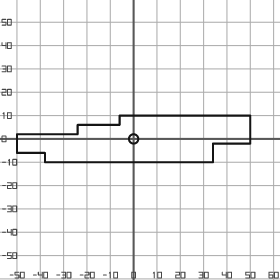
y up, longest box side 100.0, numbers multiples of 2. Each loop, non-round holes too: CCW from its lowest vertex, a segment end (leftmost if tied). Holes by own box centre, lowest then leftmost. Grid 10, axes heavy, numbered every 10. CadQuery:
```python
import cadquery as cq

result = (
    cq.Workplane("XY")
    .moveTo(-38.0, -10.0)
    .lineTo(34.0, -10.0)
    .lineTo(34.0, -2.0)
    .lineTo(50.0, -2.0)
    .lineTo(50.0, 10.0)
    .lineTo(-6.0, 10.0)
    .lineTo(-6.0, 6.0)
    .lineTo(-24.0, 6.0)
    .lineTo(-24.0, 2.0)
    .lineTo(-50.0, 2.0)
    .lineTo(-50.0, -6.0)
    .lineTo(-38.0, -6.0)
    .close()
    .moveTo(0.0, 0.0)
    .circle(2.0)
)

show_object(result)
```